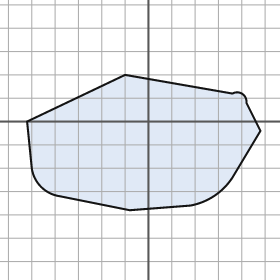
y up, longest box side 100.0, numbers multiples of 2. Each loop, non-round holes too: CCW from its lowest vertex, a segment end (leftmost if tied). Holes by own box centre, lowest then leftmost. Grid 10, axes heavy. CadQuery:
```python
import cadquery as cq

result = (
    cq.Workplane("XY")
    .moveTo(-8.0, -38.0)
    .lineTo(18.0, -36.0)
    .threePointArc((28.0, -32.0), (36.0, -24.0))
    .lineTo(48.0, -4.0)
    .lineTo(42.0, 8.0)
    .threePointArc((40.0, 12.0), (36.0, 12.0))
    .lineTo(-10.0, 20.0)
    .lineTo(-52.0, 0.0)
    .lineTo(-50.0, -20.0)
    .threePointArc((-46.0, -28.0), (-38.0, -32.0))
    .close()
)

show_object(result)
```